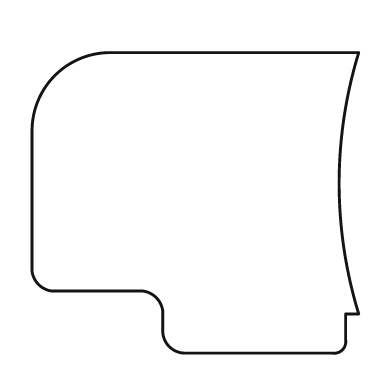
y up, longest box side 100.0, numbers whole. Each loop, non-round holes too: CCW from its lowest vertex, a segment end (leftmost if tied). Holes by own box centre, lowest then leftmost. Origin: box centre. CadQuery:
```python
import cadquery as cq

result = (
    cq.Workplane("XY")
    .moveTo(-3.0, -46.0)
    .lineTo(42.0, -46.0)
    .threePointArc((45.0, -45.0), (46.0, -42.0))
    .lineTo(46.0, -34.0)
    .lineTo(50.0, -34.0)
    .threePointArc((44.0, 6.0), (50.0, 46.0))
    .lineTo(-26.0, 46.0)
    .threePointArc((-43.0, 39.0), (-50.0, 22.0))
    .lineTo(-50.0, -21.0)
    .threePointArc((-48.0, -25.0), (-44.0, -27.0))
    .lineTo(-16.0, -27.0)
    .threePointArc((-12.0, -29.0), (-10.0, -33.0))
    .lineTo(-10.0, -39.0)
    .threePointArc((-8.0, -44.0), (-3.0, -46.0))
    .close()
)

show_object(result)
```